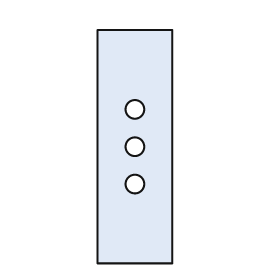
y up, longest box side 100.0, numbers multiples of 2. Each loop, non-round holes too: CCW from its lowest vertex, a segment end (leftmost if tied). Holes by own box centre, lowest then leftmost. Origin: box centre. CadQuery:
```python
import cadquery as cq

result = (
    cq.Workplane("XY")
    .moveTo(-16.0, -50.0)
    .lineTo(16.0, -50.0)
    .lineTo(16.0, 50.0)
    .lineTo(-16.0, 50.0)
    .close()
    .moveTo(0.0, -16.0)
    .circle(4.0)
    .moveTo(0.0, 0.0)
    .circle(4.0)
    .moveTo(0.0, 16.0)
    .circle(4.0)
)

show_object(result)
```